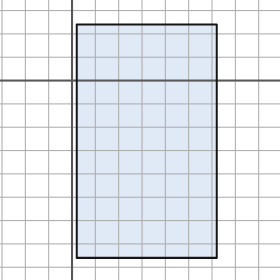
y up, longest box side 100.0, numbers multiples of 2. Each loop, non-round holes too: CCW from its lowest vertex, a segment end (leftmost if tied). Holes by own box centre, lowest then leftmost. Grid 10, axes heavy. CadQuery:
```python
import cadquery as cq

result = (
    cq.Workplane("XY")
    .moveTo(2.0, -76.0)
    .lineTo(62.0, -76.0)
    .lineTo(62.0, 24.0)
    .lineTo(2.0, 24.0)
    .close()
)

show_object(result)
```